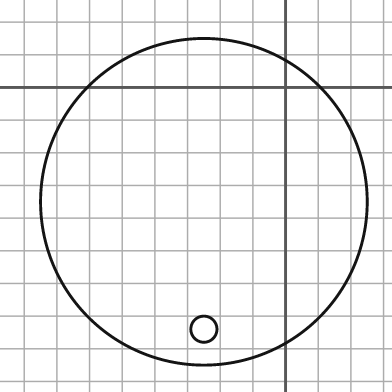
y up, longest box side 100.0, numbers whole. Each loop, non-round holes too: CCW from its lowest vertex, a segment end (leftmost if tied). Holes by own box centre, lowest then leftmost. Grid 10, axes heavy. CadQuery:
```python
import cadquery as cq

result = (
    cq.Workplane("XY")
    .moveTo(-25.0, -35.0)
    .circle(50.0)
    .moveTo(-25.0, -74.0)
    .circle(4.0)
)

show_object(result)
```